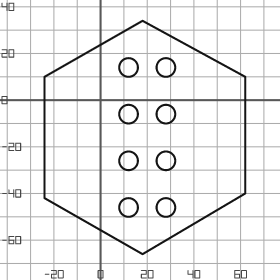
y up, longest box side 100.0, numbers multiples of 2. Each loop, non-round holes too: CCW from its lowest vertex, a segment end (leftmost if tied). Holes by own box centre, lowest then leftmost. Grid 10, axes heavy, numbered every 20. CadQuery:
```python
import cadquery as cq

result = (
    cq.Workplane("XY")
    .moveTo(18.0, -66.0)
    .lineTo(62.0, -40.0)
    .lineTo(62.0, 10.0)
    .lineTo(18.0, 34.0)
    .lineTo(-24.0, 10.0)
    .lineTo(-24.0, -42.0)
    .close()
    .moveTo(12.0, -46.0)
    .circle(4.0)
    .moveTo(28.0, -46.0)
    .circle(4.0)
    .moveTo(12.0, -26.0)
    .circle(4.0)
    .moveTo(28.0, -26.0)
    .circle(4.0)
    .moveTo(12.0, -6.0)
    .circle(4.0)
    .moveTo(28.0, -6.0)
    .circle(4.0)
    .moveTo(12.0, 14.0)
    .circle(4.0)
    .moveTo(28.0, 14.0)
    .circle(4.0)
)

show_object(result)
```